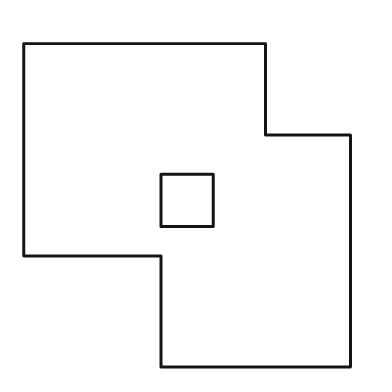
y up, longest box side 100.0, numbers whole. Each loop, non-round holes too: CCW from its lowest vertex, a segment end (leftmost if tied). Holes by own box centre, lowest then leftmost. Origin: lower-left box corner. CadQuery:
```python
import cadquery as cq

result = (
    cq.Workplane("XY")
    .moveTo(42.0, 0.0)
    .lineTo(100.0, 0.0)
    .lineTo(100.0, 71.0)
    .lineTo(74.0, 71.0)
    .lineTo(74.0, 99.0)
    .lineTo(0.0, 99.0)
    .lineTo(0.0, 34.0)
    .lineTo(42.0, 34.0)
    .close()
    .moveTo(42.0, 43.0)
    .lineTo(58.0, 43.0)
    .lineTo(58.0, 59.0)
    .lineTo(42.0, 59.0)
    .close()
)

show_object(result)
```